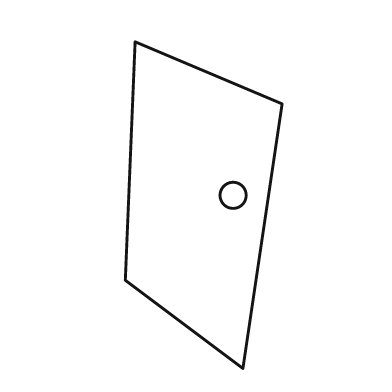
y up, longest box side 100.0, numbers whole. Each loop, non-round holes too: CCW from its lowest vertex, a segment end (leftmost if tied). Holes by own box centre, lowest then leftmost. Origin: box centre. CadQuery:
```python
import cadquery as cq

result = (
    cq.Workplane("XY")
    .moveTo(12.0, -50.0)
    .lineTo(24.0, 31.0)
    .lineTo(-21.0, 50.0)
    .lineTo(-24.0, -23.0)
    .close()
    .moveTo(9.0, 3.0)
    .circle(4.0)
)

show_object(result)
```